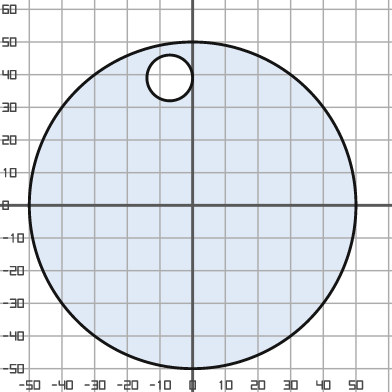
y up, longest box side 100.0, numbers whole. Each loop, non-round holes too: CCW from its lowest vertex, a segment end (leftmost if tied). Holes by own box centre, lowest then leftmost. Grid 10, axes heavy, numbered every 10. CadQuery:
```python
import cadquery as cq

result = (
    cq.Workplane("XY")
    .moveTo(0.0, 0.0)
    .circle(50.0)
    .moveTo(-7.0, 39.0)
    .circle(7.0)
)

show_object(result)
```